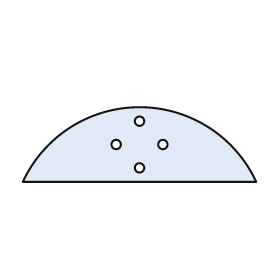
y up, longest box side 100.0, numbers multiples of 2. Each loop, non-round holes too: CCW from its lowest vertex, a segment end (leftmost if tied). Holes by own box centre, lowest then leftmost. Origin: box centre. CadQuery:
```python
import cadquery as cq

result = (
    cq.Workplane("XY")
    .moveTo(-50.0, -16.0)
    .lineTo(50.0, -16.0)
    .threePointArc((0.0, 16.0), (-50.0, -16.0))
    .close()
    .moveTo(0.0, -10.0)
    .circle(2.0)
    .moveTo(-10.0, 0.0)
    .circle(2.0)
    .moveTo(10.0, 0.0)
    .circle(2.0)
    .moveTo(0.0, 10.0)
    .circle(2.0)
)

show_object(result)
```